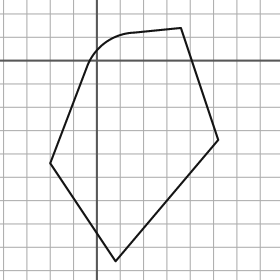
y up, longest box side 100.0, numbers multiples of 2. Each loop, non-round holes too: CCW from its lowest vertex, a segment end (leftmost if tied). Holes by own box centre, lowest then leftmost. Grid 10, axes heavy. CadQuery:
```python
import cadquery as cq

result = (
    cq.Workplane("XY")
    .moveTo(8.0, -86.0)
    .lineTo(52.0, -34.0)
    .lineTo(36.0, 14.0)
    .lineTo(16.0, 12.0)
    .threePointArc((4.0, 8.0), (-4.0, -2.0))
    .lineTo(-20.0, -44.0)
    .close()
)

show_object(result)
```